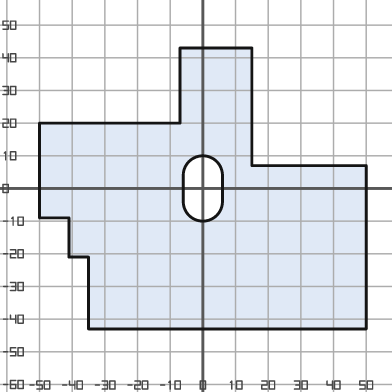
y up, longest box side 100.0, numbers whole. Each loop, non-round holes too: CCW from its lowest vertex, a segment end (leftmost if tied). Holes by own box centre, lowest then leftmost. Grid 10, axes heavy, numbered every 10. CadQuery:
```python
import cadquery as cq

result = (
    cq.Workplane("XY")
    .moveTo(-35.0, -43.0)
    .lineTo(50.0, -43.0)
    .lineTo(50.0, 7.0)
    .lineTo(15.0, 7.0)
    .lineTo(15.0, 43.0)
    .lineTo(-7.0, 43.0)
    .lineTo(-7.0, 20.0)
    .lineTo(-50.0, 20.0)
    .lineTo(-50.0, -9.0)
    .lineTo(-41.0, -9.0)
    .lineTo(-41.0, -21.0)
    .lineTo(-35.0, -21.0)
    .close()
    .moveTo(-6.0, -4.0)
    .threePointArc((0.0, -10.0), (6.0, -4.0))
    .lineTo(6.0, 4.0)
    .threePointArc((0.0, 10.0), (-6.0, 4.0))
    .close()
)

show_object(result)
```